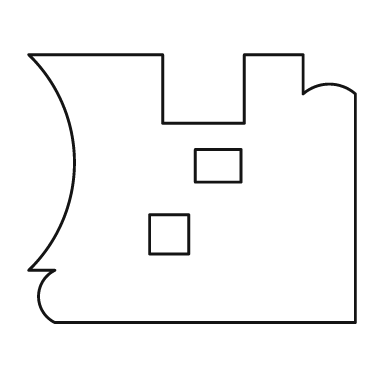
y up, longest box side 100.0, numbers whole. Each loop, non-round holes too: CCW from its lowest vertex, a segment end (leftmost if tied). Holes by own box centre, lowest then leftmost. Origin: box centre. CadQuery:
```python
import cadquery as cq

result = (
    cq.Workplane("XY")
    .moveTo(-42.0, -41.0)
    .lineTo(50.0, -41.0)
    .lineTo(50.0, 29.0)
    .threePointArc((42.0, 32.0), (34.0, 29.0))
    .lineTo(34.0, 41.0)
    .lineTo(16.0, 41.0)
    .lineTo(16.0, 20.0)
    .lineTo(-9.0, 20.0)
    .lineTo(-9.0, 41.0)
    .lineTo(-50.0, 41.0)
    .threePointArc((-36.0, 8.0), (-50.0, -25.0))
    .lineTo(-42.0, -25.0)
    .threePointArc((-47.0, -33.0), (-42.0, -41.0))
    .close()
    .moveTo(-13.0, -20.0)
    .lineTo(-1.0, -20.0)
    .lineTo(-1.0, -8.0)
    .lineTo(-13.0, -8.0)
    .close()
    .moveTo(1.0, 2.0)
    .lineTo(15.0, 2.0)
    .lineTo(15.0, 12.0)
    .lineTo(1.0, 12.0)
    .close()
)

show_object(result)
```